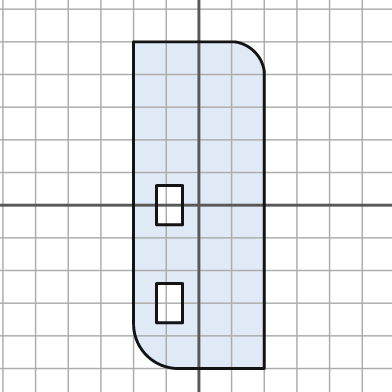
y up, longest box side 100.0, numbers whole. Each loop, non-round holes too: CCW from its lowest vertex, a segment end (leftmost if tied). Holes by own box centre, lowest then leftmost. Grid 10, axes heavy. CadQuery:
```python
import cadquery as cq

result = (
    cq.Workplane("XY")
    .moveTo(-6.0, -50.0)
    .lineTo(20.0, -50.0)
    .lineTo(20.0, 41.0)
    .threePointArc((17.0, 47.0), (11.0, 50.0))
    .lineTo(-20.0, 50.0)
    .lineTo(-20.0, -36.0)
    .threePointArc((-16.0, -46.0), (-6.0, -50.0))
    .close()
    .moveTo(-13.0, -36.0)
    .lineTo(-5.0, -36.0)
    .lineTo(-5.0, -24.0)
    .lineTo(-13.0, -24.0)
    .close()
    .moveTo(-13.0, -6.0)
    .lineTo(-5.0, -6.0)
    .lineTo(-5.0, 6.0)
    .lineTo(-13.0, 6.0)
    .close()
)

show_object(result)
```